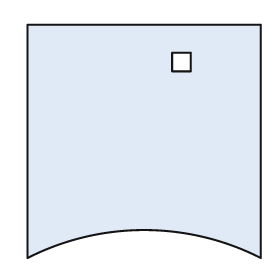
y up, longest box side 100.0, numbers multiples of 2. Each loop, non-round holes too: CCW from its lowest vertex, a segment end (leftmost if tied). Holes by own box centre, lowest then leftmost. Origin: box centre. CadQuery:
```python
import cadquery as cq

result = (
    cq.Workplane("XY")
    .moveTo(-50.0, -50.0)
    .threePointArc((0.0, -38.0), (50.0, -50.0))
    .lineTo(50.0, 50.0)
    .lineTo(-50.0, 50.0)
    .close()
    .moveTo(12.0, 30.0)
    .lineTo(20.0, 30.0)
    .lineTo(20.0, 38.0)
    .lineTo(12.0, 38.0)
    .close()
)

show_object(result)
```